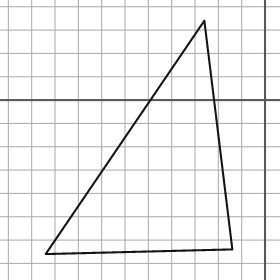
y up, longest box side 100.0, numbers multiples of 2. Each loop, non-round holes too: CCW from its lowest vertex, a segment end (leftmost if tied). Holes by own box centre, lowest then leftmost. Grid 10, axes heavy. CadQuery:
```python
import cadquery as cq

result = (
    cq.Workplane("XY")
    .moveTo(-94.0, -66.0)
    .lineTo(-14.0, -64.0)
    .lineTo(-26.0, 34.0)
    .close()
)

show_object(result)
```